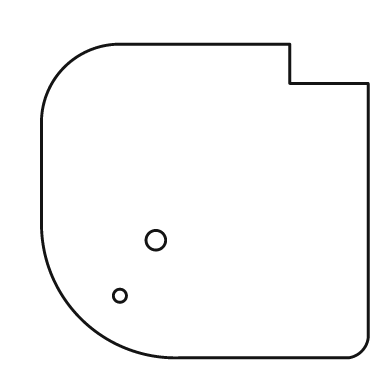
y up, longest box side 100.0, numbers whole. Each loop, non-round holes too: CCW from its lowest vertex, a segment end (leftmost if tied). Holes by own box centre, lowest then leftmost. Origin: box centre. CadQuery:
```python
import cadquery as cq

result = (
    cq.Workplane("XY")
    .moveTo(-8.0, -48.0)
    .lineTo(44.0, -48.0)
    .threePointArc((48.0, -46.0), (50.0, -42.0))
    .lineTo(50.0, 36.0)
    .lineTo(26.0, 36.0)
    .lineTo(26.0, 48.0)
    .lineTo(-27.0, 48.0)
    .threePointArc((-43.0, 41.0), (-50.0, 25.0))
    .lineTo(-50.0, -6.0)
    .threePointArc((-38.0, -36.0), (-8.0, -48.0))
    .close()
    .moveTo(-26.0, -29.0)
    .circle(2.0)
    .moveTo(-15.0, -12.0)
    .circle(3.0)
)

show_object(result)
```